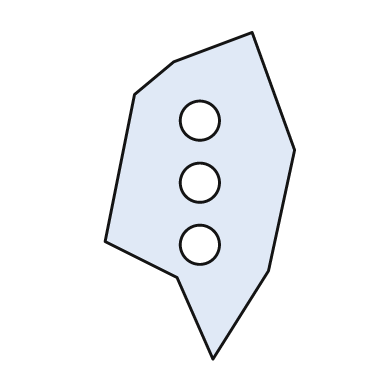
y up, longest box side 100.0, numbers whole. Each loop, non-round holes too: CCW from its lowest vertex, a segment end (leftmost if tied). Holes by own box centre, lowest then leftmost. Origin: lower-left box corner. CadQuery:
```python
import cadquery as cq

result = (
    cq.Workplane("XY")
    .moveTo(33.0, 0.0)
    .lineTo(50.0, 27.0)
    .lineTo(58.0, 64.0)
    .lineTo(45.0, 100.0)
    .lineTo(21.0, 91.0)
    .lineTo(9.0, 81.0)
    .lineTo(0.0, 36.0)
    .lineTo(22.0, 25.0)
    .close()
    .moveTo(29.0, 35.0)
    .circle(6.0)
    .moveTo(29.0, 54.0)
    .circle(6.0)
    .moveTo(29.0, 73.0)
    .circle(6.0)
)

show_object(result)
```